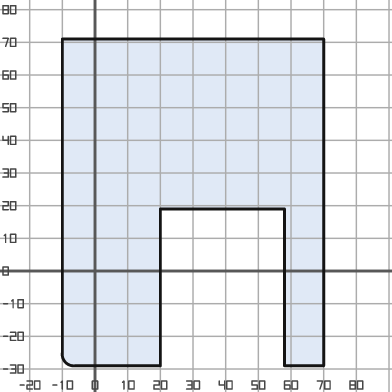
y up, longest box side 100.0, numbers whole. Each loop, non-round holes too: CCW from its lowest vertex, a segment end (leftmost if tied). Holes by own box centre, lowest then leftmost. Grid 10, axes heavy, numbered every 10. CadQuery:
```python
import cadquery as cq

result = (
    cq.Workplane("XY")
    .moveTo(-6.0, -29.0)
    .lineTo(20.0, -29.0)
    .lineTo(20.0, 19.0)
    .lineTo(58.0, 19.0)
    .lineTo(58.0, -29.0)
    .lineTo(70.0, -29.0)
    .lineTo(70.0, 71.0)
    .lineTo(-10.0, 71.0)
    .lineTo(-10.0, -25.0)
    .threePointArc((-9.0, -28.0), (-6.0, -29.0))
    .close()
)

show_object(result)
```